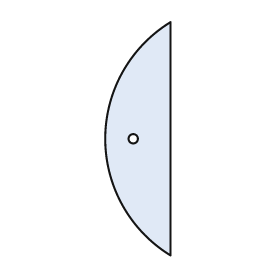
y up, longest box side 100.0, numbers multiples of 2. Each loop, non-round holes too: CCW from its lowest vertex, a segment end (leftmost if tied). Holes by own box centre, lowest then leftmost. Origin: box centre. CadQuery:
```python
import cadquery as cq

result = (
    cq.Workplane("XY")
    .moveTo(14.0, -50.0)
    .lineTo(14.0, 50.0)
    .threePointArc((-14.0, 0.0), (14.0, -50.0))
    .close()
    .moveTo(-2.0, 0.0)
    .circle(2.0)
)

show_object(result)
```